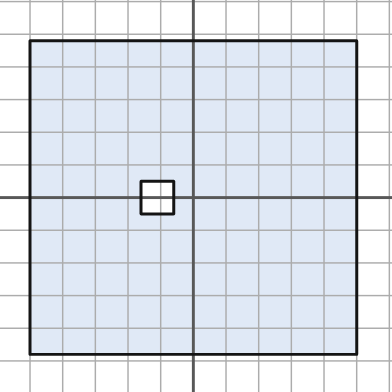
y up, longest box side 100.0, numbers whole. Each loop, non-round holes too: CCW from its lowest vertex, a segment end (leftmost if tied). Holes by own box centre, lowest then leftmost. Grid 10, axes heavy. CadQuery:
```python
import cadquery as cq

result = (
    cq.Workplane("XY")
    .moveTo(-50.0, -48.0)
    .lineTo(50.0, -48.0)
    .lineTo(50.0, 48.0)
    .lineTo(-50.0, 48.0)
    .close()
    .moveTo(-16.0, -5.0)
    .lineTo(-6.0, -5.0)
    .lineTo(-6.0, 5.0)
    .lineTo(-16.0, 5.0)
    .close()
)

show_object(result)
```